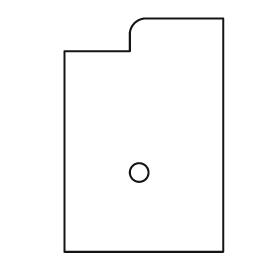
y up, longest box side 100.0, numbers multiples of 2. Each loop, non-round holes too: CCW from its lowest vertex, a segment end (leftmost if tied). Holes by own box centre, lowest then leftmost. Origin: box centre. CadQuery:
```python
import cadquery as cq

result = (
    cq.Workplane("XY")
    .moveTo(-34.0, -50.0)
    .lineTo(34.0, -50.0)
    .lineTo(34.0, 50.0)
    .lineTo(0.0, 50.0)
    .threePointArc((-4.0, 48.0), (-6.0, 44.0))
    .lineTo(-6.0, 36.0)
    .lineTo(-34.0, 36.0)
    .close()
    .moveTo(-2.0, -16.0)
    .circle(4.0)
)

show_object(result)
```